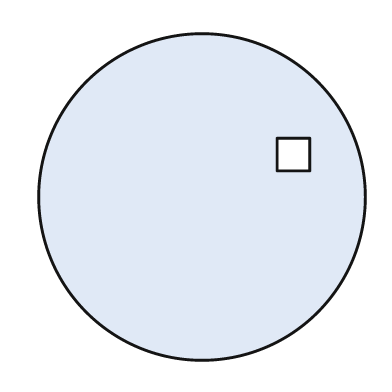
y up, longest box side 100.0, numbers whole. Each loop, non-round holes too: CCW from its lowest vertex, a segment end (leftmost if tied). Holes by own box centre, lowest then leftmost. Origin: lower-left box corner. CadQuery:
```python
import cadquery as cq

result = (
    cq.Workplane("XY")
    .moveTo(50.0, 50.0)
    .circle(50.0)
    .moveTo(73.0, 58.0)
    .lineTo(83.0, 58.0)
    .lineTo(83.0, 68.0)
    .lineTo(73.0, 68.0)
    .close()
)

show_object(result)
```